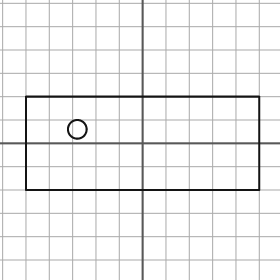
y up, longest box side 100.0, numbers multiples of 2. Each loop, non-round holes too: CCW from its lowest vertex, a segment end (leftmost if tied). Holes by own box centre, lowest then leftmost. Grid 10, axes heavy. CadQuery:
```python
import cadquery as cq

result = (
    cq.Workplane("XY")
    .moveTo(-50.0, -20.0)
    .lineTo(50.0, -20.0)
    .lineTo(50.0, 20.0)
    .lineTo(-50.0, 20.0)
    .close()
    .moveTo(-28.0, 6.0)
    .circle(4.0)
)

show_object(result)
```